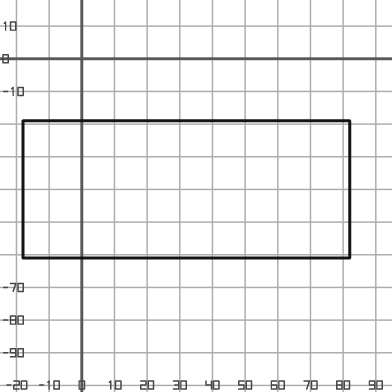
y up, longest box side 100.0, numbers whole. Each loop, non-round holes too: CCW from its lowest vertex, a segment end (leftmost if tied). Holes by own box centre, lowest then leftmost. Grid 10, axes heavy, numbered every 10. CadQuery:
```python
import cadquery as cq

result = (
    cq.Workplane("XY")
    .moveTo(-18.0, -61.0)
    .lineTo(82.0, -61.0)
    .lineTo(82.0, -19.0)
    .lineTo(-18.0, -19.0)
    .close()
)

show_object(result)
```